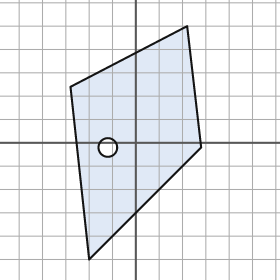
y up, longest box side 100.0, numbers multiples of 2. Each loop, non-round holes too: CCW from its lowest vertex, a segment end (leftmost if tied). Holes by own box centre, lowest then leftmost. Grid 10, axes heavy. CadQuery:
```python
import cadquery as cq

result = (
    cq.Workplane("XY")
    .moveTo(-20.0, -50.0)
    .lineTo(28.0, -2.0)
    .lineTo(22.0, 50.0)
    .lineTo(-28.0, 24.0)
    .close()
    .moveTo(-12.0, -2.0)
    .circle(4.0)
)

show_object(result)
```